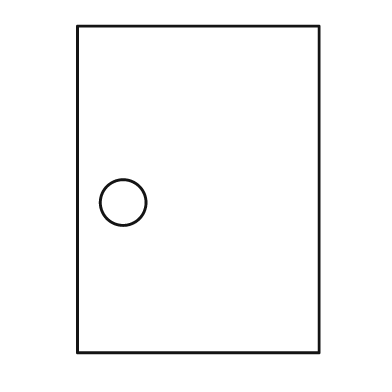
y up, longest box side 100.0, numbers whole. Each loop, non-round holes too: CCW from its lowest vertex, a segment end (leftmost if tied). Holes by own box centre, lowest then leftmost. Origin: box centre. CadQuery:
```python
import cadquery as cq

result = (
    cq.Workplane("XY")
    .moveTo(-37.0, -50.0)
    .lineTo(37.0, -50.0)
    .lineTo(37.0, 50.0)
    .lineTo(-37.0, 50.0)
    .close()
    .moveTo(-23.0, -4.0)
    .circle(7.0)
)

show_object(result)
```